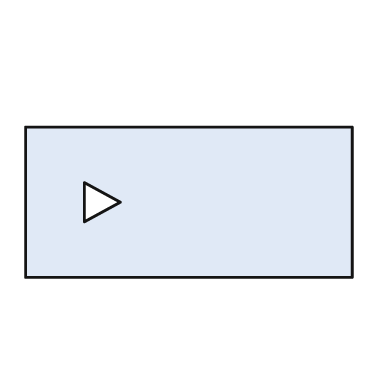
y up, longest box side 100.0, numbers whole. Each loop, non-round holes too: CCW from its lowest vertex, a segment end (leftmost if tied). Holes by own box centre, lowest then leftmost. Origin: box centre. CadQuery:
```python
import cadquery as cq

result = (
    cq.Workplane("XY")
    .moveTo(-50.0, -23.0)
    .lineTo(50.0, -23.0)
    .lineTo(50.0, 23.0)
    .lineTo(-50.0, 23.0)
    .close()
    .moveTo(-32.0, -6.0)
    .lineTo(-21.0, 0.0)
    .lineTo(-32.0, 6.0)
    .close()
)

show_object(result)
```